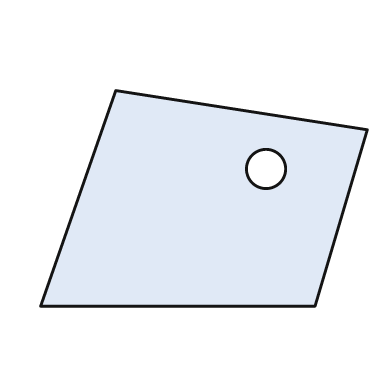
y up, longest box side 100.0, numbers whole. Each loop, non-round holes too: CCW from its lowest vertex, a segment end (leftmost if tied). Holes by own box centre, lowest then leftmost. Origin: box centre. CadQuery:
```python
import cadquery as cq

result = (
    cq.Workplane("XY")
    .moveTo(-50.0, -33.0)
    .lineTo(34.0, -33.0)
    .lineTo(50.0, 21.0)
    .lineTo(-27.0, 33.0)
    .close()
    .moveTo(19.0, 9.0)
    .circle(6.0)
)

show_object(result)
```